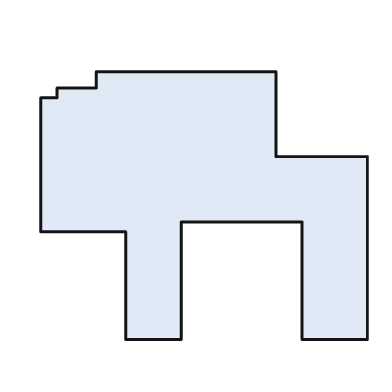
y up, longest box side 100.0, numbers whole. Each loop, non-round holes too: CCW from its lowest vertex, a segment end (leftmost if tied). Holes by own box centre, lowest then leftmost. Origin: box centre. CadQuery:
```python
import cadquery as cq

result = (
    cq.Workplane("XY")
    .moveTo(-24.0, -41.0)
    .lineTo(-7.0, -41.0)
    .lineTo(-7.0, -5.0)
    .lineTo(30.0, -5.0)
    .lineTo(30.0, -41.0)
    .lineTo(50.0, -41.0)
    .lineTo(50.0, 15.0)
    .lineTo(22.0, 15.0)
    .lineTo(22.0, 41.0)
    .lineTo(-33.0, 41.0)
    .lineTo(-33.0, 36.0)
    .lineTo(-45.0, 36.0)
    .lineTo(-45.0, 33.0)
    .lineTo(-50.0, 33.0)
    .lineTo(-50.0, -8.0)
    .lineTo(-24.0, -8.0)
    .close()
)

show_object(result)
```